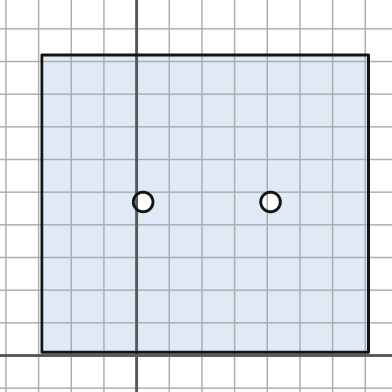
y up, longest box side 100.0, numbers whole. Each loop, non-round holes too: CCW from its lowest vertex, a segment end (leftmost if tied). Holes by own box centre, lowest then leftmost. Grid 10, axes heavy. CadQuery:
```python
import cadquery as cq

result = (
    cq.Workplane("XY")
    .moveTo(-29.0, 1.0)
    .lineTo(71.0, 1.0)
    .lineTo(71.0, 92.0)
    .lineTo(-29.0, 92.0)
    .close()
    .moveTo(2.0, 47.0)
    .circle(3.0)
    .moveTo(41.0, 47.0)
    .circle(3.0)
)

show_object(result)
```